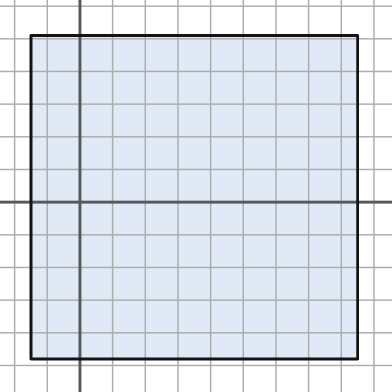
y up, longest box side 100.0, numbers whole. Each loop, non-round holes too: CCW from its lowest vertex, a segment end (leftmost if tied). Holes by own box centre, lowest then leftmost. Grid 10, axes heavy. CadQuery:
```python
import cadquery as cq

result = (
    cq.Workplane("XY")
    .moveTo(-15.0, -48.0)
    .lineTo(85.0, -48.0)
    .lineTo(85.0, 51.0)
    .lineTo(-15.0, 51.0)
    .close()
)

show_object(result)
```